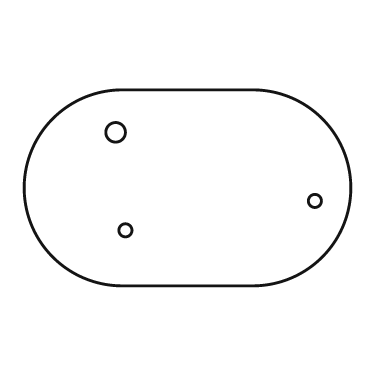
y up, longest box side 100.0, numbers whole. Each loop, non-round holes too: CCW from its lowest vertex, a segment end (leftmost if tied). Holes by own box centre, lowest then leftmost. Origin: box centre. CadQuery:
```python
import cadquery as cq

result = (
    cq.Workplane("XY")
    .moveTo(-20.0, -30.0)
    .lineTo(20.0, -30.0)
    .threePointArc((50.0, 0.0), (20.0, 30.0))
    .lineTo(-20.0, 30.0)
    .threePointArc((-50.0, 0.0), (-20.0, -30.0))
    .close()
    .moveTo(-19.0, -13.0)
    .circle(2.0)
    .moveTo(39.0, -4.0)
    .circle(2.0)
    .moveTo(-22.0, 17.0)
    .circle(3.0)
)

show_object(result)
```